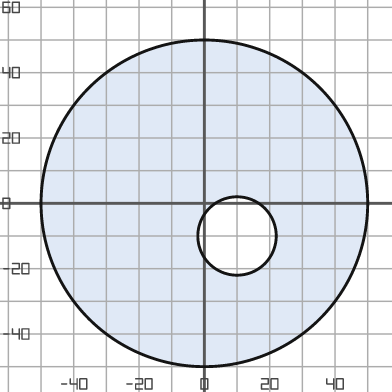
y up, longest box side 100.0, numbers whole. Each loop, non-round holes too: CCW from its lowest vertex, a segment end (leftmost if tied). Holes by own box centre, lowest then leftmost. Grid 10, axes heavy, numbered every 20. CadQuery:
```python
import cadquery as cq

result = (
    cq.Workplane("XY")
    .moveTo(0.0, 0.0)
    .circle(50.0)
    .moveTo(10.0, -10.0)
    .circle(12.0)
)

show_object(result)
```